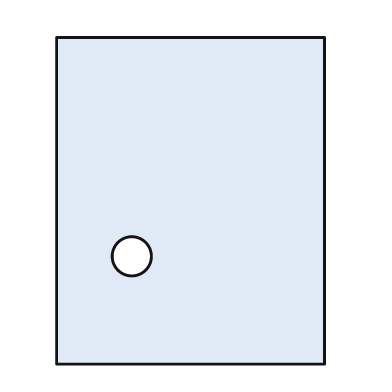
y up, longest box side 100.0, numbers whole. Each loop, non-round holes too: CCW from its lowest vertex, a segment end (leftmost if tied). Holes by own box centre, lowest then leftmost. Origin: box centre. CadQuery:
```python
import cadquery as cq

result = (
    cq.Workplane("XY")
    .moveTo(-41.0, -50.0)
    .lineTo(41.0, -50.0)
    .lineTo(41.0, 50.0)
    .lineTo(-41.0, 50.0)
    .close()
    .moveTo(-18.0, -17.0)
    .circle(6.0)
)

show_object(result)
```